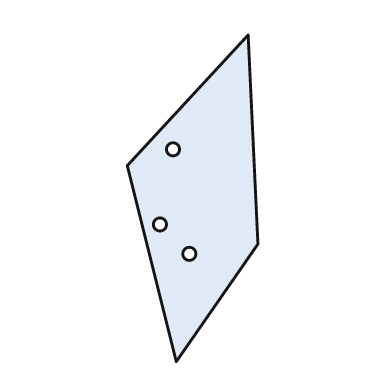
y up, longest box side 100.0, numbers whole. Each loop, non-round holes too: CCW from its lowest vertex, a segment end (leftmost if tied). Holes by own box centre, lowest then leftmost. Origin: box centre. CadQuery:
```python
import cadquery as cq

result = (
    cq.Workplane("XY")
    .moveTo(-5.0, -50.0)
    .lineTo(20.0, -14.0)
    .lineTo(17.0, 50.0)
    .lineTo(-20.0, 10.0)
    .close()
    .moveTo(-1.0, -17.0)
    .circle(2.0)
    .moveTo(-10.0, -8.0)
    .circle(2.0)
    .moveTo(-6.0, 15.0)
    .circle(2.0)
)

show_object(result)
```